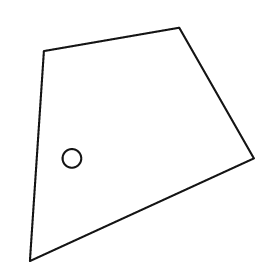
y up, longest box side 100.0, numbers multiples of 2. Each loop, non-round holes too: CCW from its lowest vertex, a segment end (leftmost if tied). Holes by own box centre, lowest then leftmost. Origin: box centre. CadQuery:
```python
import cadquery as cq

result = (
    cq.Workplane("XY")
    .moveTo(-48.0, -50.0)
    .lineTo(48.0, -6.0)
    .lineTo(16.0, 50.0)
    .lineTo(-42.0, 40.0)
    .close()
    .moveTo(-30.0, -6.0)
    .circle(4.0)
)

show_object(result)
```